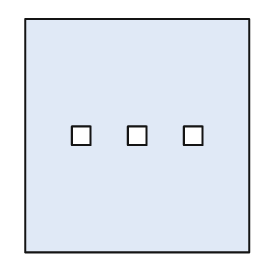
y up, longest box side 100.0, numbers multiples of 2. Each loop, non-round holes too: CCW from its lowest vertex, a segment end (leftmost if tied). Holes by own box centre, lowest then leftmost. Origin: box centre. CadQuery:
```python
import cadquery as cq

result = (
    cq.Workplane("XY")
    .moveTo(-48.0, -50.0)
    .lineTo(48.0, -50.0)
    .lineTo(48.0, 50.0)
    .lineTo(-48.0, 50.0)
    .close()
    .moveTo(-28.0, -4.0)
    .lineTo(-20.0, -4.0)
    .lineTo(-20.0, 4.0)
    .lineTo(-28.0, 4.0)
    .close()
    .moveTo(-4.0, -4.0)
    .lineTo(4.0, -4.0)
    .lineTo(4.0, 4.0)
    .lineTo(-4.0, 4.0)
    .close()
    .moveTo(20.0, -4.0)
    .lineTo(28.0, -4.0)
    .lineTo(28.0, 4.0)
    .lineTo(20.0, 4.0)
    .close()
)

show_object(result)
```